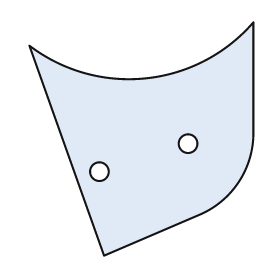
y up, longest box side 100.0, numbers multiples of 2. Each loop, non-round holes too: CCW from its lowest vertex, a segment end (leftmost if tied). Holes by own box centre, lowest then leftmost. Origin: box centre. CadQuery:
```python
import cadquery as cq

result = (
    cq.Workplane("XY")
    .moveTo(-16.0, -50.0)
    .lineTo(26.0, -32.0)
    .threePointArc((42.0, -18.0), (48.0, 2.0))
    .lineTo(48.0, 50.0)
    .threePointArc((2.0, 26.0), (-48.0, 40.0))
    .close()
    .moveTo(-18.0, -14.0)
    .circle(4.0)
    .moveTo(20.0, -2.0)
    .circle(4.0)
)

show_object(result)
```